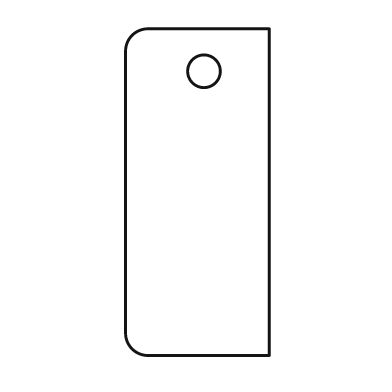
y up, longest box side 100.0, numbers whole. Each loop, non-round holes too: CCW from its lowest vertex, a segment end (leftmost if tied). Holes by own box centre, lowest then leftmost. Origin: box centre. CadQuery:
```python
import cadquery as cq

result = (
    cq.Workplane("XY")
    .moveTo(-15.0, -50.0)
    .lineTo(22.0, -50.0)
    .lineTo(22.0, 50.0)
    .lineTo(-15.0, 50.0)
    .threePointArc((-20.0, 48.0), (-22.0, 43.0))
    .lineTo(-22.0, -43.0)
    .threePointArc((-20.0, -48.0), (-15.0, -50.0))
    .close()
    .moveTo(2.0, 37.0)
    .circle(5.0)
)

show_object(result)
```